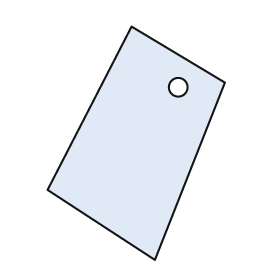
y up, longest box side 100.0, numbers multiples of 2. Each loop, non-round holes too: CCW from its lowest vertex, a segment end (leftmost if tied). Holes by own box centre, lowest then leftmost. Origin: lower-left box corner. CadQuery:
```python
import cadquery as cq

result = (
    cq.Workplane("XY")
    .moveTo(46.0, 0.0)
    .lineTo(76.0, 76.0)
    .lineTo(36.0, 100.0)
    .lineTo(0.0, 30.0)
    .close()
    .moveTo(56.0, 74.0)
    .circle(4.0)
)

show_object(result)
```